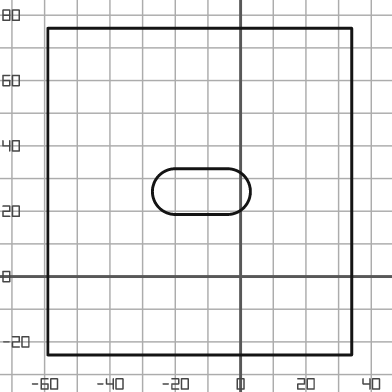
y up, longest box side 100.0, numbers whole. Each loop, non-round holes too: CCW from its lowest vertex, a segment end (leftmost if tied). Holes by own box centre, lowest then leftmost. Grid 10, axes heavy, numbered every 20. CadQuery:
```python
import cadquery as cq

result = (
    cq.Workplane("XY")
    .moveTo(-59.0, -24.0)
    .lineTo(34.0, -24.0)
    .lineTo(34.0, 76.0)
    .lineTo(-59.0, 76.0)
    .close()
    .moveTo(-20.0, 19.0)
    .lineTo(-4.0, 19.0)
    .threePointArc((3.0, 26.0), (-4.0, 33.0))
    .lineTo(-20.0, 33.0)
    .threePointArc((-27.0, 26.0), (-20.0, 19.0))
    .close()
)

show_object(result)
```